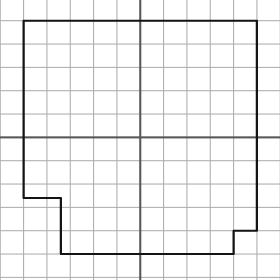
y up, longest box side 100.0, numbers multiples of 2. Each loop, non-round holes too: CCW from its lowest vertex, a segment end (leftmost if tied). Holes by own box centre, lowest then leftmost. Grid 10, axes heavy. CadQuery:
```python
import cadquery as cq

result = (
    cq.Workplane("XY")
    .moveTo(-34.0, -50.0)
    .lineTo(40.0, -50.0)
    .lineTo(40.0, -40.0)
    .lineTo(50.0, -40.0)
    .lineTo(50.0, 50.0)
    .lineTo(-50.0, 50.0)
    .lineTo(-50.0, -26.0)
    .lineTo(-34.0, -26.0)
    .close()
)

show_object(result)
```